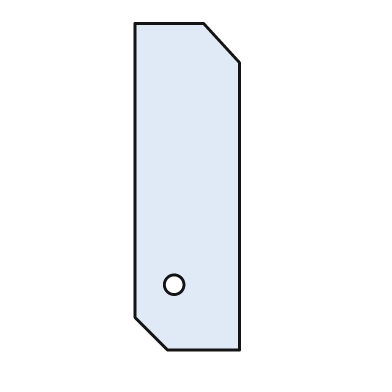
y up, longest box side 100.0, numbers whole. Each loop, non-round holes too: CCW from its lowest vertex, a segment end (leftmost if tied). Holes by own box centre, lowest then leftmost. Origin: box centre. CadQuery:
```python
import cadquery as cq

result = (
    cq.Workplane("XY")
    .moveTo(-6.0, -50.0)
    .lineTo(16.0, -50.0)
    .lineTo(16.0, 38.0)
    .lineTo(5.0, 50.0)
    .lineTo(-16.0, 50.0)
    .lineTo(-16.0, -40.0)
    .close()
    .moveTo(-4.0, -30.0)
    .circle(3.0)
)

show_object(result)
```